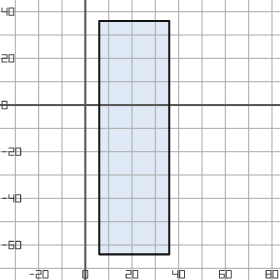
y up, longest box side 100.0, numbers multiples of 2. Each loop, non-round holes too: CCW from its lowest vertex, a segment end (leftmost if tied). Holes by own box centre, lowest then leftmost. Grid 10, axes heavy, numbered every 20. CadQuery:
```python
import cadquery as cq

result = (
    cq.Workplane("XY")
    .moveTo(6.0, -64.0)
    .lineTo(36.0, -64.0)
    .lineTo(36.0, 36.0)
    .lineTo(6.0, 36.0)
    .close()
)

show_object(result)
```